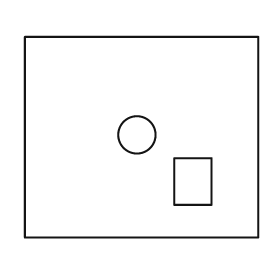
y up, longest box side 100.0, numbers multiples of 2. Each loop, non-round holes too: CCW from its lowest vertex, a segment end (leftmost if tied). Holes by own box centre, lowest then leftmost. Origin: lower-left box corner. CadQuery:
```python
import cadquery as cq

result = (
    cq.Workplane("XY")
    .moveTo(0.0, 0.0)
    .lineTo(100.0, 0.0)
    .lineTo(100.0, 86.0)
    .lineTo(0.0, 86.0)
    .close()
    .moveTo(64.0, 14.0)
    .lineTo(80.0, 14.0)
    .lineTo(80.0, 34.0)
    .lineTo(64.0, 34.0)
    .close()
    .moveTo(48.0, 44.0)
    .circle(8.0)
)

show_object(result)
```